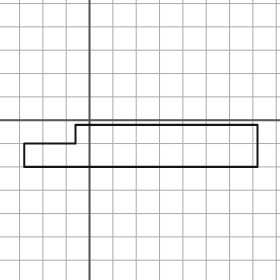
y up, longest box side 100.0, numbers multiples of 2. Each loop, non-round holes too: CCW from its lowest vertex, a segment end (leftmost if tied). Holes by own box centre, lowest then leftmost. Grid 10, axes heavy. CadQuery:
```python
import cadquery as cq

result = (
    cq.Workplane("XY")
    .moveTo(-28.0, -20.0)
    .lineTo(72.0, -20.0)
    .lineTo(72.0, -2.0)
    .lineTo(-6.0, -2.0)
    .lineTo(-6.0, -10.0)
    .lineTo(-28.0, -10.0)
    .close()
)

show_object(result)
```